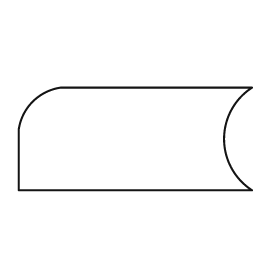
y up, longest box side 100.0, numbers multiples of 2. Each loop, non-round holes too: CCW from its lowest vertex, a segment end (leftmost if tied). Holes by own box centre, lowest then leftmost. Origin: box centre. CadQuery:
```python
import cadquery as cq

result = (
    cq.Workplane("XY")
    .moveTo(-50.0, -22.0)
    .lineTo(50.0, -22.0)
    .threePointArc((38.0, 0.0), (50.0, 22.0))
    .lineTo(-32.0, 22.0)
    .threePointArc((-44.0, 16.0), (-50.0, 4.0))
    .close()
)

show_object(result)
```